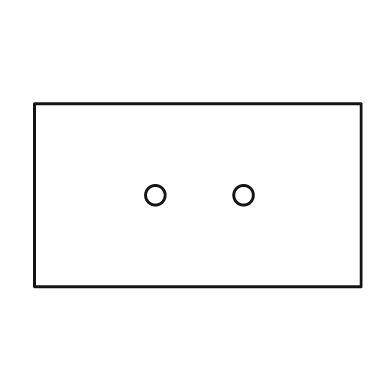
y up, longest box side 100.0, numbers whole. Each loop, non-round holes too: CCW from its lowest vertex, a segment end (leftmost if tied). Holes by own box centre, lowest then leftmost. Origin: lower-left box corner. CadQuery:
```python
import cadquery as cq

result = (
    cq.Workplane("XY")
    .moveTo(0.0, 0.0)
    .lineTo(100.0, 0.0)
    .lineTo(100.0, 56.0)
    .lineTo(0.0, 56.0)
    .close()
    .moveTo(37.0, 28.0)
    .circle(3.0)
    .moveTo(64.0, 28.0)
    .circle(3.0)
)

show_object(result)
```